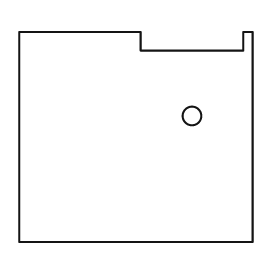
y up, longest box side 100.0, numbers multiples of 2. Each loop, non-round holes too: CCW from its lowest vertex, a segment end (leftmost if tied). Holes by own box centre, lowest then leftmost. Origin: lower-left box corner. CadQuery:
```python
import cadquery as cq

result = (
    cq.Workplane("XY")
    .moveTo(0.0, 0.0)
    .lineTo(100.0, 0.0)
    .lineTo(100.0, 90.0)
    .lineTo(96.0, 90.0)
    .lineTo(96.0, 82.0)
    .lineTo(52.0, 82.0)
    .lineTo(52.0, 90.0)
    .lineTo(0.0, 90.0)
    .close()
    .moveTo(74.0, 54.0)
    .circle(4.0)
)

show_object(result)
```